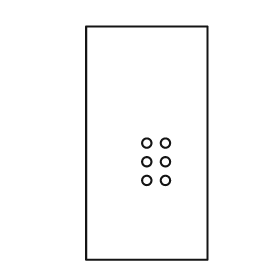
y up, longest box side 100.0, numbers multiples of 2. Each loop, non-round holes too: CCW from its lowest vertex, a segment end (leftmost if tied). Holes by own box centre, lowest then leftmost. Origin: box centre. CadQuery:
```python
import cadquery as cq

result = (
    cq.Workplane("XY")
    .moveTo(-26.0, -50.0)
    .lineTo(26.0, -50.0)
    .lineTo(26.0, 50.0)
    .lineTo(-26.0, 50.0)
    .close()
    .moveTo(0.0, -16.0)
    .circle(2.0)
    .moveTo(8.0, -16.0)
    .circle(2.0)
    .moveTo(0.0, -8.0)
    .circle(2.0)
    .moveTo(8.0, -8.0)
    .circle(2.0)
    .moveTo(0.0, 0.0)
    .circle(2.0)
    .moveTo(8.0, 0.0)
    .circle(2.0)
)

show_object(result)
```